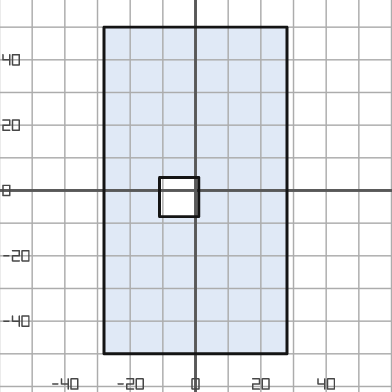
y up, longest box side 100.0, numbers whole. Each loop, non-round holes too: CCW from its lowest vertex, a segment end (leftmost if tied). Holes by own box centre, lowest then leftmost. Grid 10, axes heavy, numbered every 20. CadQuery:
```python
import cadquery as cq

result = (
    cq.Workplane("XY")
    .moveTo(-28.0, -50.0)
    .lineTo(28.0, -50.0)
    .lineTo(28.0, 50.0)
    .lineTo(-28.0, 50.0)
    .close()
    .moveTo(-11.0, -8.0)
    .lineTo(1.0, -8.0)
    .lineTo(1.0, 4.0)
    .lineTo(-11.0, 4.0)
    .close()
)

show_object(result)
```